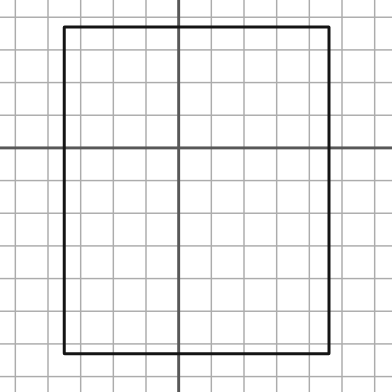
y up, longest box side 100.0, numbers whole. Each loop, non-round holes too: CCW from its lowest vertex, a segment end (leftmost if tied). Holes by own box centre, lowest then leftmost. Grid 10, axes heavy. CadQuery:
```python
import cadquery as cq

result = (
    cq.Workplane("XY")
    .moveTo(-35.0, -63.0)
    .lineTo(46.0, -63.0)
    .lineTo(46.0, 37.0)
    .lineTo(-35.0, 37.0)
    .close()
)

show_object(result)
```